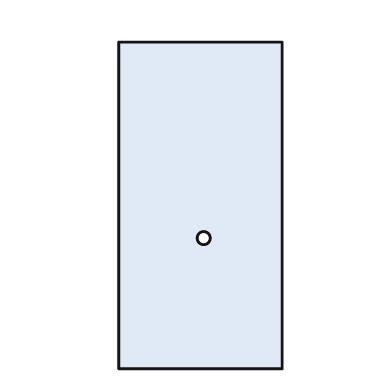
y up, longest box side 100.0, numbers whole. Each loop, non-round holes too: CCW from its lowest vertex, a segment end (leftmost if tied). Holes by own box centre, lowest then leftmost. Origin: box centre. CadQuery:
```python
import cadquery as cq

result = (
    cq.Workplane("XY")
    .moveTo(-25.0, -50.0)
    .lineTo(25.0, -50.0)
    .lineTo(25.0, 50.0)
    .lineTo(-25.0, 50.0)
    .close()
    .moveTo(1.0, -10.0)
    .circle(2.0)
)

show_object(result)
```